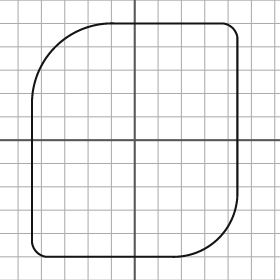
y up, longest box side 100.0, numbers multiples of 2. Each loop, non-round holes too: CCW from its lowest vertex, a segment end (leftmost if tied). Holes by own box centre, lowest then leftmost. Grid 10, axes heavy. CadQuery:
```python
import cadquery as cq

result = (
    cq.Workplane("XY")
    .moveTo(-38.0, -50.0)
    .lineTo(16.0, -50.0)
    .threePointArc((36.0, -42.0), (44.0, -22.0))
    .lineTo(44.0, 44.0)
    .threePointArc((42.0, 48.0), (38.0, 50.0))
    .lineTo(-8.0, 50.0)
    .threePointArc((-34.0, 40.0), (-44.0, 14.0))
    .lineTo(-44.0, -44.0)
    .threePointArc((-42.0, -48.0), (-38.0, -50.0))
    .close()
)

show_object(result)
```